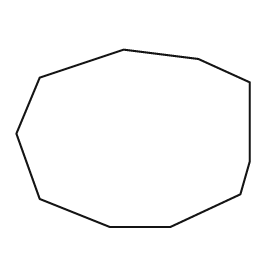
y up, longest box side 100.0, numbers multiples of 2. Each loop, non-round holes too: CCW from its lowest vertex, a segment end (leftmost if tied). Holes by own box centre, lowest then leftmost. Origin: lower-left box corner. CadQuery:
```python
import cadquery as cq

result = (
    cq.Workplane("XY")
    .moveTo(40.0, 0.0)
    .lineTo(66.0, 0.0)
    .lineTo(96.0, 14.0)
    .lineTo(100.0, 28.0)
    .lineTo(100.0, 62.0)
    .lineTo(78.0, 72.0)
    .lineTo(46.0, 76.0)
    .lineTo(10.0, 64.0)
    .lineTo(0.0, 40.0)
    .lineTo(10.0, 12.0)
    .close()
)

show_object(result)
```